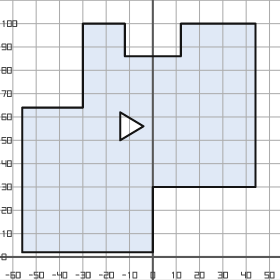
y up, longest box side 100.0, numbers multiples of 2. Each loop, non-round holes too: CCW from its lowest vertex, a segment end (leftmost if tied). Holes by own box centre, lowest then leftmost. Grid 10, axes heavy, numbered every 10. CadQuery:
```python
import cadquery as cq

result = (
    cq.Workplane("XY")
    .moveTo(-56.0, 2.0)
    .lineTo(0.0, 2.0)
    .lineTo(0.0, 30.0)
    .lineTo(44.0, 30.0)
    .lineTo(44.0, 100.0)
    .lineTo(12.0, 100.0)
    .lineTo(12.0, 86.0)
    .lineTo(-12.0, 86.0)
    .lineTo(-12.0, 100.0)
    .lineTo(-30.0, 100.0)
    .lineTo(-30.0, 64.0)
    .lineTo(-56.0, 64.0)
    .close()
    .moveTo(-14.0, 50.0)
    .lineTo(-4.0, 56.0)
    .lineTo(-14.0, 62.0)
    .close()
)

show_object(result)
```